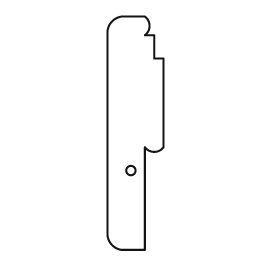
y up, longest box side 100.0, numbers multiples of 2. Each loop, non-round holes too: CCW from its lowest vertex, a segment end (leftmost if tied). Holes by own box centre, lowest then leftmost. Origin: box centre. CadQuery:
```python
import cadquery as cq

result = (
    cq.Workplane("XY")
    .moveTo(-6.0, -50.0)
    .lineTo(4.0, -50.0)
    .lineTo(4.0, -6.0)
    .threePointArc((8.0, -8.0), (12.0, -6.0))
    .lineTo(12.0, 32.0)
    .lineTo(8.0, 32.0)
    .lineTo(8.0, 42.0)
    .lineTo(4.0, 42.0)
    .threePointArc((6.0, 46.0), (4.0, 50.0))
    .lineTo(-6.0, 50.0)
    .threePointArc((-10.0, 48.0), (-12.0, 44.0))
    .lineTo(-12.0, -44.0)
    .threePointArc((-10.0, -48.0), (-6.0, -50.0))
    .close()
    .moveTo(-2.0, -16.0)
    .circle(2.0)
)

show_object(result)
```